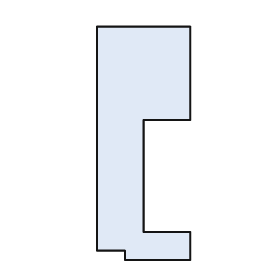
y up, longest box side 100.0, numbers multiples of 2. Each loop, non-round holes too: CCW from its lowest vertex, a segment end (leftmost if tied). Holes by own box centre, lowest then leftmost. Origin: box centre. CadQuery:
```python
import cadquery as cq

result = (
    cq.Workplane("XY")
    .moveTo(-8.0, -50.0)
    .lineTo(20.0, -50.0)
    .lineTo(20.0, -38.0)
    .lineTo(0.0, -38.0)
    .lineTo(0.0, 10.0)
    .lineTo(20.0, 10.0)
    .lineTo(20.0, 50.0)
    .lineTo(-20.0, 50.0)
    .lineTo(-20.0, -46.0)
    .lineTo(-8.0, -46.0)
    .close()
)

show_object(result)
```